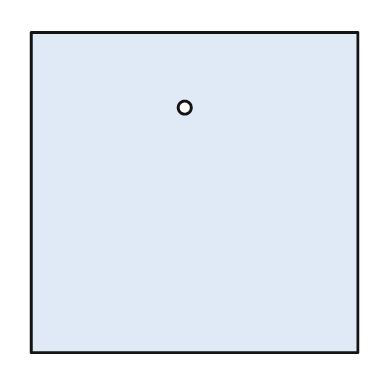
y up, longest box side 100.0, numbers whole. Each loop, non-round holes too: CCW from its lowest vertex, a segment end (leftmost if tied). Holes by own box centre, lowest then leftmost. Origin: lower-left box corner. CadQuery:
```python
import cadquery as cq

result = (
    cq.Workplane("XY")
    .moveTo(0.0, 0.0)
    .lineTo(100.0, 0.0)
    .lineTo(100.0, 98.0)
    .lineTo(0.0, 98.0)
    .close()
    .moveTo(47.0, 75.0)
    .circle(2.0)
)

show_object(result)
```